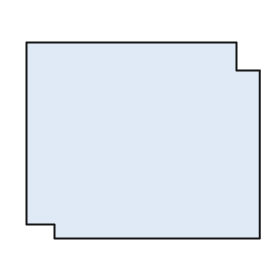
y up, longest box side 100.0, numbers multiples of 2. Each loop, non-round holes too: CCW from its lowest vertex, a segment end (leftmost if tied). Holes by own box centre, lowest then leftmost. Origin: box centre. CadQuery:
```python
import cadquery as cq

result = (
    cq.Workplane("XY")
    .moveTo(-38.0, -42.0)
    .lineTo(50.0, -42.0)
    .lineTo(50.0, 30.0)
    .lineTo(40.0, 30.0)
    .lineTo(40.0, 42.0)
    .lineTo(-50.0, 42.0)
    .lineTo(-50.0, -36.0)
    .lineTo(-38.0, -36.0)
    .close()
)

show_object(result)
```